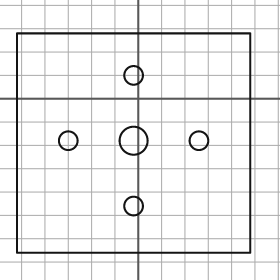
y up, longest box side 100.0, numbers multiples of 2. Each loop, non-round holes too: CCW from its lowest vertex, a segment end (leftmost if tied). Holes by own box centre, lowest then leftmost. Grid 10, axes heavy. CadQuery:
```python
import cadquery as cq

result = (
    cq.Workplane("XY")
    .moveTo(-52.0, -66.0)
    .lineTo(48.0, -66.0)
    .lineTo(48.0, 28.0)
    .lineTo(-52.0, 28.0)
    .close()
    .moveTo(-2.0, -46.0)
    .circle(4.0)
    .moveTo(-30.0, -18.0)
    .circle(4.0)
    .moveTo(-2.0, -18.0)
    .circle(6.0)
    .moveTo(26.0, -18.0)
    .circle(4.0)
    .moveTo(-2.0, 10.0)
    .circle(4.0)
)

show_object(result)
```